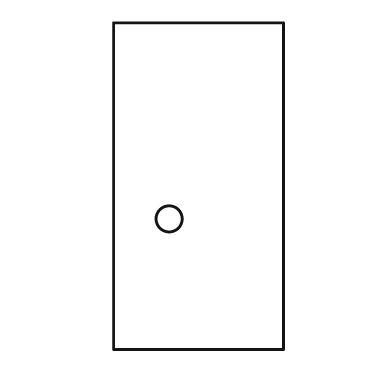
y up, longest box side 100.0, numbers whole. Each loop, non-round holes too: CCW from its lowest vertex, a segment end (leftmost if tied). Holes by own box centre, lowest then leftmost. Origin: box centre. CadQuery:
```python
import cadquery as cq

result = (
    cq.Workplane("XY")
    .moveTo(-26.0, -50.0)
    .lineTo(26.0, -50.0)
    .lineTo(26.0, 50.0)
    .lineTo(-26.0, 50.0)
    .close()
    .moveTo(-9.0, -10.0)
    .circle(4.0)
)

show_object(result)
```